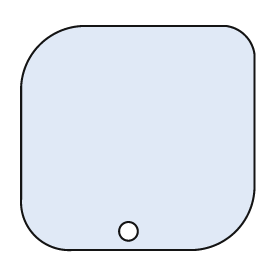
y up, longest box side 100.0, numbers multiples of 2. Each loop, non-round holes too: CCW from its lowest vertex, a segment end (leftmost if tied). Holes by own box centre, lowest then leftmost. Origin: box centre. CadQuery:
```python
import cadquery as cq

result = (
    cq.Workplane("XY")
    .moveTo(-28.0, -48.0)
    .lineTo(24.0, -48.0)
    .threePointArc((42.0, -40.0), (50.0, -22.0))
    .lineTo(50.0, 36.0)
    .threePointArc((46.0, 44.0), (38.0, 48.0))
    .lineTo(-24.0, 48.0)
    .threePointArc((-42.0, 40.0), (-50.0, 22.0))
    .lineTo(-50.0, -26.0)
    .threePointArc((-44.0, -42.0), (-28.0, -48.0))
    .close()
    .moveTo(-4.0, -40.0)
    .circle(4.0)
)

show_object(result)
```